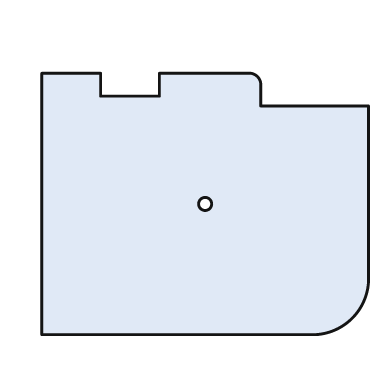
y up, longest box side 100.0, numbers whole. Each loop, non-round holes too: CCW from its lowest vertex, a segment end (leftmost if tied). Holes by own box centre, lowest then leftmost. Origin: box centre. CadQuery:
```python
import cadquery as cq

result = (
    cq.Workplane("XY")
    .moveTo(-50.0, -40.0)
    .lineTo(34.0, -40.0)
    .threePointArc((45.0, -35.0), (50.0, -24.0))
    .lineTo(50.0, 30.0)
    .lineTo(17.0, 30.0)
    .lineTo(17.0, 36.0)
    .threePointArc((16.0, 39.0), (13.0, 40.0))
    .lineTo(-14.0, 40.0)
    .lineTo(-14.0, 33.0)
    .lineTo(-32.0, 33.0)
    .lineTo(-32.0, 40.0)
    .lineTo(-50.0, 40.0)
    .close()
    .moveTo(0.0, 0.0)
    .circle(2.0)
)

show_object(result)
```